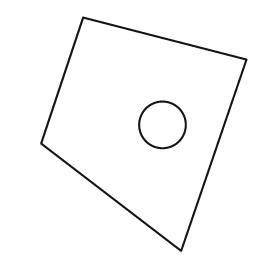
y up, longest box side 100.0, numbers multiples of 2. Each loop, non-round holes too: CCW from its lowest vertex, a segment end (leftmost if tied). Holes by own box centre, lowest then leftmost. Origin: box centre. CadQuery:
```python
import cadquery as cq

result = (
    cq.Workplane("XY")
    .moveTo(16.0, -50.0)
    .lineTo(44.0, 32.0)
    .lineTo(-26.0, 50.0)
    .lineTo(-44.0, -4.0)
    .close()
    .moveTo(8.0, 4.0)
    .circle(10.0)
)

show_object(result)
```